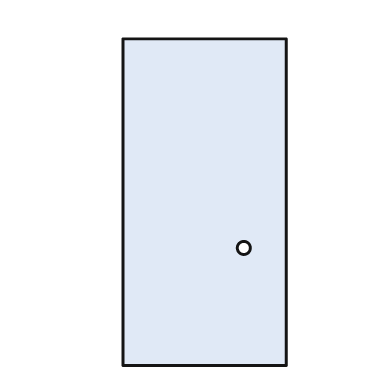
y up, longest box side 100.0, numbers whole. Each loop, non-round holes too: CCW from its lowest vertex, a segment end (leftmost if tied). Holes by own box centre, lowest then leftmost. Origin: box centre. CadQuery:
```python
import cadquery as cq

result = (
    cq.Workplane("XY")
    .moveTo(-25.0, -50.0)
    .lineTo(25.0, -50.0)
    .lineTo(25.0, 50.0)
    .lineTo(-25.0, 50.0)
    .close()
    .moveTo(12.0, -14.0)
    .circle(2.0)
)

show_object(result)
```